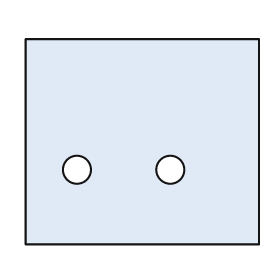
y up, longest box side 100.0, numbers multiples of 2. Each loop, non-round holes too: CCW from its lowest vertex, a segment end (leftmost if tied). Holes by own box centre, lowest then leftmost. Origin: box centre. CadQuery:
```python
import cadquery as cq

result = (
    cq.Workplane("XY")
    .moveTo(-50.0, -44.0)
    .lineTo(50.0, -44.0)
    .lineTo(50.0, 44.0)
    .lineTo(-50.0, 44.0)
    .close()
    .moveTo(-28.0, -12.0)
    .circle(6.0)
    .moveTo(12.0, -12.0)
    .circle(6.0)
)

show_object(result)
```